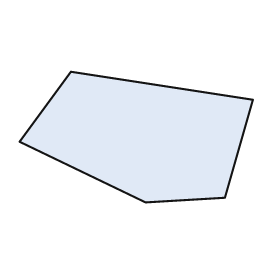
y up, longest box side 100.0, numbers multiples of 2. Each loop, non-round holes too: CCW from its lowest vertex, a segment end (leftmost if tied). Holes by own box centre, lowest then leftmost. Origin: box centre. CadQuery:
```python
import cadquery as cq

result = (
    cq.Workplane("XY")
    .moveTo(4.0, -28.0)
    .lineTo(38.0, -26.0)
    .lineTo(50.0, 16.0)
    .lineTo(-28.0, 28.0)
    .lineTo(-50.0, -2.0)
    .close()
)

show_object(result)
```